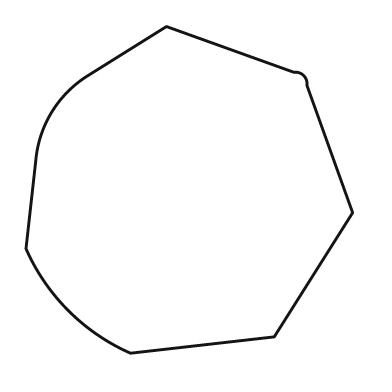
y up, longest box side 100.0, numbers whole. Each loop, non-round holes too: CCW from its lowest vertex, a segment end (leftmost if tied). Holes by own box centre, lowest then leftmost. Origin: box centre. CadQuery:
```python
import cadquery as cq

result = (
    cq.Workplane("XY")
    .moveTo(-18.0, -50.0)
    .lineTo(26.0, -45.0)
    .lineTo(50.0, -7.0)
    .lineTo(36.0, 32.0)
    .threePointArc((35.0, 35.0), (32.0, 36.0))
    .lineTo(-7.0, 50.0)
    .lineTo(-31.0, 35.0)
    .threePointArc((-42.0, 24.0), (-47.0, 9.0))
    .lineTo(-50.0, -18.0)
    .threePointArc((-37.0, -37.0), (-18.0, -50.0))
    .close()
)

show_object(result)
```